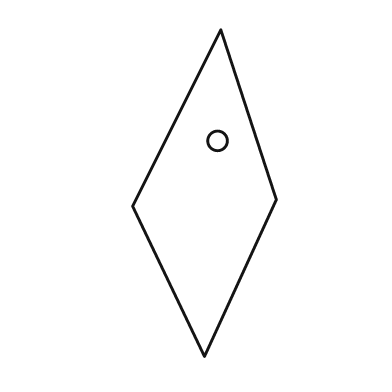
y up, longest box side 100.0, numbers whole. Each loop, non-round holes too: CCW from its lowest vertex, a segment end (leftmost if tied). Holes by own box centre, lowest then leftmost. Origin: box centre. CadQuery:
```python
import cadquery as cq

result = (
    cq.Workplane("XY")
    .moveTo(0.0, -50.0)
    .lineTo(22.0, -2.0)
    .lineTo(5.0, 50.0)
    .lineTo(-22.0, -4.0)
    .close()
    .moveTo(4.0, 16.0)
    .circle(3.0)
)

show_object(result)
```